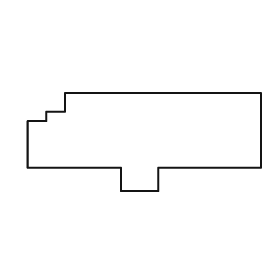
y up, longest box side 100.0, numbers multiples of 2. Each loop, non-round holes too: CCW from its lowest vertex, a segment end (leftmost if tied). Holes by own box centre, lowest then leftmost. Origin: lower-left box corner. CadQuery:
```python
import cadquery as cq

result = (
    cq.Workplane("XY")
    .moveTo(40.0, 0.0)
    .lineTo(56.0, 0.0)
    .lineTo(56.0, 10.0)
    .lineTo(100.0, 10.0)
    .lineTo(100.0, 42.0)
    .lineTo(16.0, 42.0)
    .lineTo(16.0, 34.0)
    .lineTo(8.0, 34.0)
    .lineTo(8.0, 30.0)
    .lineTo(0.0, 30.0)
    .lineTo(0.0, 10.0)
    .lineTo(40.0, 10.0)
    .close()
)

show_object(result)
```